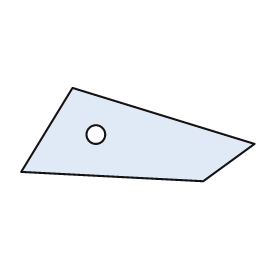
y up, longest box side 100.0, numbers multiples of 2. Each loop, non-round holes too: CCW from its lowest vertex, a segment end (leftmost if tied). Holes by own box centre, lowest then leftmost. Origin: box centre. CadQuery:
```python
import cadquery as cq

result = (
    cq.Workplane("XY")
    .moveTo(28.0, -20.0)
    .lineTo(50.0, -4.0)
    .lineTo(-28.0, 20.0)
    .lineTo(-50.0, -16.0)
    .close()
    .moveTo(-18.0, 0.0)
    .circle(4.0)
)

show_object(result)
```